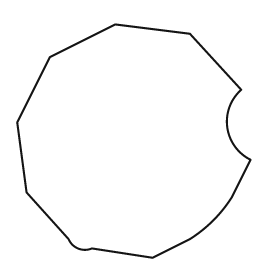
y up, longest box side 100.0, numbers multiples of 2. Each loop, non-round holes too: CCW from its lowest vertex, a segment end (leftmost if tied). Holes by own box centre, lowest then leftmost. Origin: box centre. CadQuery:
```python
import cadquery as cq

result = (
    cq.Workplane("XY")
    .moveTo(8.0, -50.0)
    .lineTo(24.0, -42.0)
    .threePointArc((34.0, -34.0), (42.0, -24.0))
    .lineTo(50.0, -8.0)
    .threePointArc((40.0, 6.0), (46.0, 22.0))
    .lineTo(24.0, 46.0)
    .lineTo(-8.0, 50.0)
    .lineTo(-36.0, 36.0)
    .lineTo(-50.0, 8.0)
    .lineTo(-46.0, -22.0)
    .lineTo(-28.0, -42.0)
    .threePointArc((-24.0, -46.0), (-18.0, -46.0))
    .close()
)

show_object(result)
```